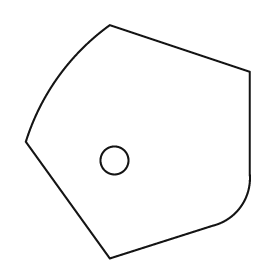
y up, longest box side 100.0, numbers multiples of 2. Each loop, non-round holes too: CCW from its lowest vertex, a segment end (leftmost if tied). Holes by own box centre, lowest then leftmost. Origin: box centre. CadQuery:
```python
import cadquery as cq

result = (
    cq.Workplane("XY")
    .moveTo(-12.0, -50.0)
    .lineTo(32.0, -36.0)
    .threePointArc((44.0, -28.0), (48.0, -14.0))
    .lineTo(48.0, 30.0)
    .lineTo(-12.0, 50.0)
    .threePointArc((-34.0, 28.0), (-48.0, 0.0))
    .close()
    .moveTo(-10.0, -8.0)
    .circle(6.0)
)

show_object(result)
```